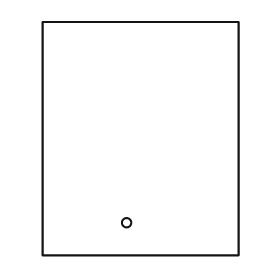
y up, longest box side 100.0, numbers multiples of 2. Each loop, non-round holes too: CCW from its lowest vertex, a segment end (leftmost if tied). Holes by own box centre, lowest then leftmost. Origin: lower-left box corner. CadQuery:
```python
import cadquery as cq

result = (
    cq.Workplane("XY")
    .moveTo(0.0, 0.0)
    .lineTo(84.0, 0.0)
    .lineTo(84.0, 100.0)
    .lineTo(0.0, 100.0)
    .close()
    .moveTo(36.0, 14.0)
    .circle(2.0)
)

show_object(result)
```